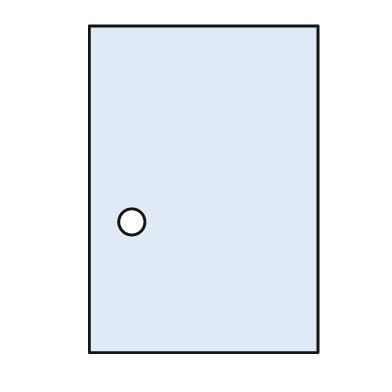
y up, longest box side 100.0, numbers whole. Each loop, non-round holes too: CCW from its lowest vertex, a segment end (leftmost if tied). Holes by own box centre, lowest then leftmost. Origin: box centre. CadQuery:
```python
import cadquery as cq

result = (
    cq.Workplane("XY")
    .moveTo(-35.0, -50.0)
    .lineTo(35.0, -50.0)
    .lineTo(35.0, 50.0)
    .lineTo(-35.0, 50.0)
    .close()
    .moveTo(-22.0, -10.0)
    .circle(4.0)
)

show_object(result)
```